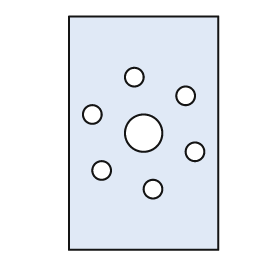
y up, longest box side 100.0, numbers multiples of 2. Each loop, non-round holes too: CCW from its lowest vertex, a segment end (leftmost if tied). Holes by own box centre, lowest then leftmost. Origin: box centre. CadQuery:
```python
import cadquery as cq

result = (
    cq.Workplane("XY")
    .moveTo(-32.0, -50.0)
    .lineTo(32.0, -50.0)
    .lineTo(32.0, 50.0)
    .lineTo(-32.0, 50.0)
    .close()
    .moveTo(4.0, -24.0)
    .circle(4.0)
    .moveTo(-18.0, -16.0)
    .circle(4.0)
    .moveTo(22.0, -8.0)
    .circle(4.0)
    .moveTo(0.0, 0.0)
    .circle(8.0)
    .moveTo(-22.0, 8.0)
    .circle(4.0)
    .moveTo(18.0, 16.0)
    .circle(4.0)
    .moveTo(-4.0, 24.0)
    .circle(4.0)
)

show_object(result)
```